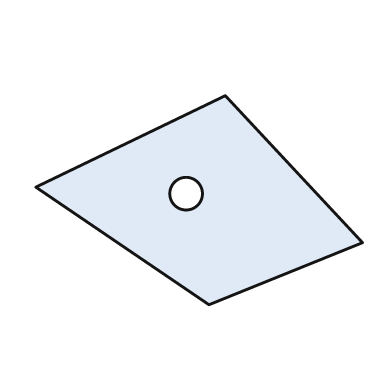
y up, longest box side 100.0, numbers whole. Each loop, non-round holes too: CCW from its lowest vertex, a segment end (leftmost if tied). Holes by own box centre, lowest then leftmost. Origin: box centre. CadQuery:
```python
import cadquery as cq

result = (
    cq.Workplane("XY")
    .moveTo(3.0, -32.0)
    .lineTo(50.0, -13.0)
    .lineTo(8.0, 32.0)
    .lineTo(-50.0, 4.0)
    .close()
    .moveTo(-4.0, 2.0)
    .circle(5.0)
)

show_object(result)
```